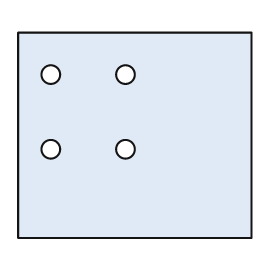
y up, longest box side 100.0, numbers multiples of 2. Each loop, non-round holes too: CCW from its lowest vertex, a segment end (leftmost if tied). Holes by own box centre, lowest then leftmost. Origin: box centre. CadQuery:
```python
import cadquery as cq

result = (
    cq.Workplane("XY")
    .moveTo(-50.0, -44.0)
    .lineTo(50.0, -44.0)
    .lineTo(50.0, 44.0)
    .lineTo(-50.0, 44.0)
    .close()
    .moveTo(-36.0, -6.0)
    .circle(4.0)
    .moveTo(-4.0, -6.0)
    .circle(4.0)
    .moveTo(-36.0, 26.0)
    .circle(4.0)
    .moveTo(-4.0, 26.0)
    .circle(4.0)
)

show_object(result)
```